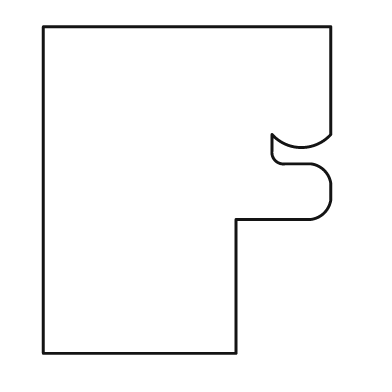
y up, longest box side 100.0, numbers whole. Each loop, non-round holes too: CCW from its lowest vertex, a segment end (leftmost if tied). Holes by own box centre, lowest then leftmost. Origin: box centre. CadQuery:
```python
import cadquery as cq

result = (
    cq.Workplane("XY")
    .moveTo(-44.0, -50.0)
    .lineTo(15.0, -50.0)
    .lineTo(15.0, -9.0)
    .lineTo(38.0, -9.0)
    .threePointArc((42.0, -7.0), (44.0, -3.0))
    .lineTo(44.0, 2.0)
    .threePointArc((42.0, 6.0), (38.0, 8.0))
    .lineTo(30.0, 8.0)
    .threePointArc((27.0, 9.0), (26.0, 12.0))
    .lineTo(26.0, 17.0)
    .threePointArc((35.0, 13.0), (44.0, 17.0))
    .lineTo(44.0, 50.0)
    .lineTo(-44.0, 50.0)
    .close()
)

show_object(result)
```